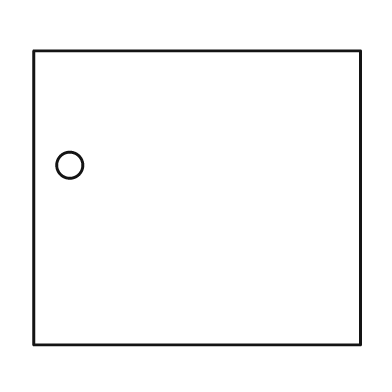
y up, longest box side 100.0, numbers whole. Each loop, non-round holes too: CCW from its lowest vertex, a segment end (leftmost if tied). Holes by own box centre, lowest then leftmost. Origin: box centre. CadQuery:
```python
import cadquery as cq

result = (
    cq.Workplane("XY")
    .moveTo(-50.0, -45.0)
    .lineTo(50.0, -45.0)
    .lineTo(50.0, 45.0)
    .lineTo(-50.0, 45.0)
    .close()
    .moveTo(-39.0, 10.0)
    .circle(4.0)
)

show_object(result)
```